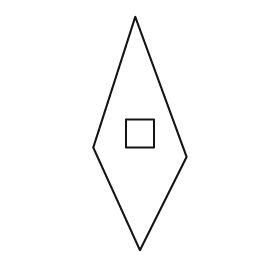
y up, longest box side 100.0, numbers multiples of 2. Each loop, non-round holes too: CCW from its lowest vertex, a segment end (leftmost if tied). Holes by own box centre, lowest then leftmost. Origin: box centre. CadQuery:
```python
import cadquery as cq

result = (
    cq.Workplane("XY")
    .moveTo(0.0, -50.0)
    .lineTo(20.0, -10.0)
    .lineTo(-2.0, 50.0)
    .lineTo(-20.0, -6.0)
    .close()
    .moveTo(-6.0, -6.0)
    .lineTo(6.0, -6.0)
    .lineTo(6.0, 6.0)
    .lineTo(-6.0, 6.0)
    .close()
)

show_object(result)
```